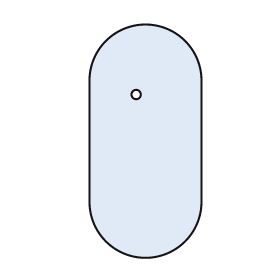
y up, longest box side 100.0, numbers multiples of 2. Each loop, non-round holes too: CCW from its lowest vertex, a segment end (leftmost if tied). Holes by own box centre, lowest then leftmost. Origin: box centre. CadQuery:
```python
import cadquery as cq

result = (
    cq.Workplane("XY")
    .moveTo(-24.0, -26.0)
    .threePointArc((0.0, -50.0), (24.0, -26.0))
    .lineTo(24.0, 26.0)
    .threePointArc((0.0, 50.0), (-24.0, 26.0))
    .close()
    .moveTo(-4.0, 20.0)
    .circle(2.0)
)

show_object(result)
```